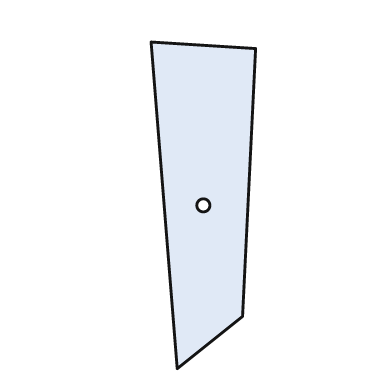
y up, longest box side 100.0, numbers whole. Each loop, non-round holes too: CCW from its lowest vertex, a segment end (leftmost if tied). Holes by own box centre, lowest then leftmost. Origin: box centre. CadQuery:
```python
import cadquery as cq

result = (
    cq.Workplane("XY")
    .moveTo(-8.0, -50.0)
    .lineTo(12.0, -34.0)
    .lineTo(16.0, 48.0)
    .lineTo(-16.0, 50.0)
    .close()
    .moveTo(0.0, 0.0)
    .circle(2.0)
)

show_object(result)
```